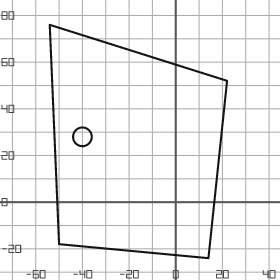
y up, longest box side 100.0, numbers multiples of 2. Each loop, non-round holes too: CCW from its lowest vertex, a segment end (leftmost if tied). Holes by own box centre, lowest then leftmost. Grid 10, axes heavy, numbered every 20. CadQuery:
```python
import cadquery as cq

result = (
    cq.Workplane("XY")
    .moveTo(14.0, -24.0)
    .lineTo(22.0, 52.0)
    .lineTo(-54.0, 76.0)
    .lineTo(-50.0, -18.0)
    .close()
    .moveTo(-40.0, 28.0)
    .circle(4.0)
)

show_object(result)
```